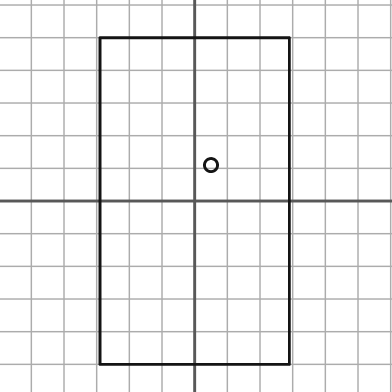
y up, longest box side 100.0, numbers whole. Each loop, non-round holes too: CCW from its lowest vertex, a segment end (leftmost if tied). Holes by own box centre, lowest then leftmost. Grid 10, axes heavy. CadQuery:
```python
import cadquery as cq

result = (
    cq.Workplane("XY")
    .moveTo(-29.0, -50.0)
    .lineTo(29.0, -50.0)
    .lineTo(29.0, 50.0)
    .lineTo(-29.0, 50.0)
    .close()
    .moveTo(5.0, 11.0)
    .circle(2.0)
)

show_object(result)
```